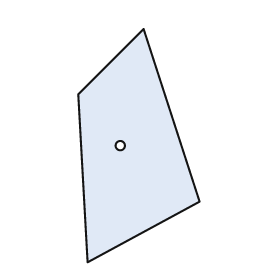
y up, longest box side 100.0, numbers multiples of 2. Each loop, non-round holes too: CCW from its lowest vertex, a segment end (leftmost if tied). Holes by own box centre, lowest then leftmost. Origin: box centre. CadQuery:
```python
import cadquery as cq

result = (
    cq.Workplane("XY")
    .moveTo(-22.0, -50.0)
    .lineTo(26.0, -24.0)
    .lineTo(2.0, 50.0)
    .lineTo(-26.0, 22.0)
    .close()
    .moveTo(-8.0, 0.0)
    .circle(2.0)
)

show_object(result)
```